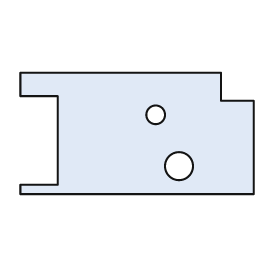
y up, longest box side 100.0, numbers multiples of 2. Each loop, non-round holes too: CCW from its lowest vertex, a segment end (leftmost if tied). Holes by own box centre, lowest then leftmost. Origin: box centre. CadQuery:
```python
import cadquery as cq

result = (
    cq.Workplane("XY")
    .moveTo(-50.0, -26.0)
    .lineTo(50.0, -26.0)
    .lineTo(50.0, 14.0)
    .lineTo(36.0, 14.0)
    .lineTo(36.0, 26.0)
    .lineTo(-50.0, 26.0)
    .lineTo(-50.0, 16.0)
    .lineTo(-34.0, 16.0)
    .lineTo(-34.0, -22.0)
    .lineTo(-50.0, -22.0)
    .close()
    .moveTo(18.0, -14.0)
    .circle(6.0)
    .moveTo(8.0, 8.0)
    .circle(4.0)
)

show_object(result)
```